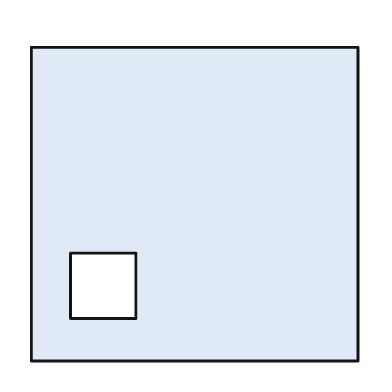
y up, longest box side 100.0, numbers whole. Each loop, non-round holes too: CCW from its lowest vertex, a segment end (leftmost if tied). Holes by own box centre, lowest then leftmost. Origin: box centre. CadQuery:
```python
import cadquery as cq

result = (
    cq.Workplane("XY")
    .moveTo(-50.0, -48.0)
    .lineTo(50.0, -48.0)
    .lineTo(50.0, 48.0)
    .lineTo(-50.0, 48.0)
    .close()
    .moveTo(-38.0, -35.0)
    .lineTo(-18.0, -35.0)
    .lineTo(-18.0, -15.0)
    .lineTo(-38.0, -15.0)
    .close()
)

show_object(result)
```